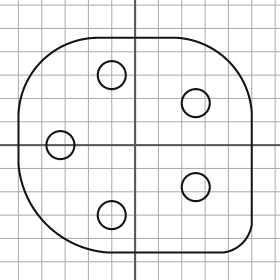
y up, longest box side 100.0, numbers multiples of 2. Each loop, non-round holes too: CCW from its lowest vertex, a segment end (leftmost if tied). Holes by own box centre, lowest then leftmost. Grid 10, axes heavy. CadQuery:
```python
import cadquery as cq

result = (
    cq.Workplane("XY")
    .moveTo(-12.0, -46.0)
    .lineTo(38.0, -46.0)
    .threePointArc((46.0, -42.0), (50.0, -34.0))
    .lineTo(50.0, 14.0)
    .threePointArc((40.0, 36.0), (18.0, 46.0))
    .lineTo(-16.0, 46.0)
    .threePointArc((-40.0, 36.0), (-50.0, 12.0))
    .lineTo(-50.0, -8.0)
    .threePointArc((-38.0, -34.0), (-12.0, -46.0))
    .close()
    .moveTo(-10.0, -30.0)
    .circle(6.0)
    .moveTo(26.0, -18.0)
    .circle(6.0)
    .moveTo(-32.0, 0.0)
    .circle(6.0)
    .moveTo(26.0, 18.0)
    .circle(6.0)
    .moveTo(-10.0, 30.0)
    .circle(6.0)
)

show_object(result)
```